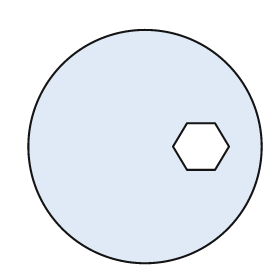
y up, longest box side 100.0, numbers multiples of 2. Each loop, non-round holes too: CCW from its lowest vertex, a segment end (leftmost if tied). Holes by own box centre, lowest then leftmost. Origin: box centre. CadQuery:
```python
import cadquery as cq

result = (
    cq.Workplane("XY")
    .moveTo(0.0, 0.0)
    .circle(50.0)
    .moveTo(18.0, -10.0)
    .lineTo(30.0, -10.0)
    .lineTo(36.0, 0.0)
    .lineTo(30.0, 10.0)
    .lineTo(18.0, 10.0)
    .lineTo(12.0, 0.0)
    .close()
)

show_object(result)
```